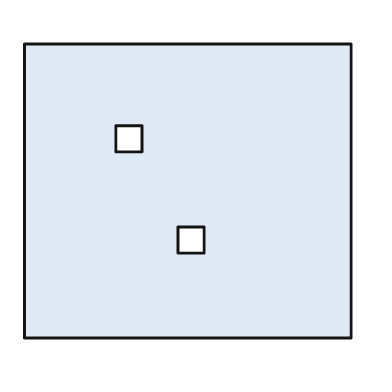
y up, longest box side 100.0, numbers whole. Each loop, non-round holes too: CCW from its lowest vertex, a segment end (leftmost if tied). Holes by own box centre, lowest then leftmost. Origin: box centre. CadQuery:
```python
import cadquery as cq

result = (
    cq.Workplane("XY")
    .moveTo(-50.0, -45.0)
    .lineTo(50.0, -45.0)
    .lineTo(50.0, 45.0)
    .lineTo(-50.0, 45.0)
    .close()
    .moveTo(-3.0, -19.0)
    .lineTo(5.0, -19.0)
    .lineTo(5.0, -11.0)
    .lineTo(-3.0, -11.0)
    .close()
    .moveTo(-22.0, 12.0)
    .lineTo(-14.0, 12.0)
    .lineTo(-14.0, 20.0)
    .lineTo(-22.0, 20.0)
    .close()
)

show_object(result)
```